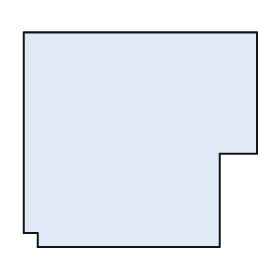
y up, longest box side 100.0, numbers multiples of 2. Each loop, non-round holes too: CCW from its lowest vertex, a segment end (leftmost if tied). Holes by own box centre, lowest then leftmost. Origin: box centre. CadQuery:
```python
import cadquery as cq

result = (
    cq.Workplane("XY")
    .moveTo(-44.0, -46.0)
    .lineTo(34.0, -46.0)
    .lineTo(34.0, -6.0)
    .lineTo(50.0, -6.0)
    .lineTo(50.0, 46.0)
    .lineTo(-50.0, 46.0)
    .lineTo(-50.0, -40.0)
    .lineTo(-44.0, -40.0)
    .close()
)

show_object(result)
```